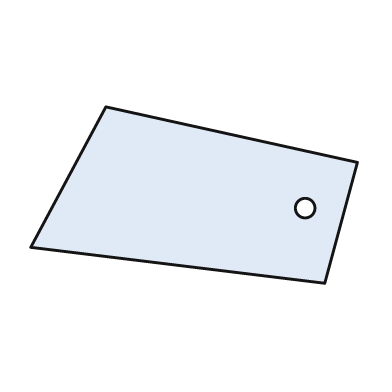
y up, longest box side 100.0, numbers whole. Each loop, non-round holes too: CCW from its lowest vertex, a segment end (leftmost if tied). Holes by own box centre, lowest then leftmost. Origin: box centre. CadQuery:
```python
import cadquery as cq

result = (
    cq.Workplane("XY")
    .moveTo(40.0, -27.0)
    .lineTo(50.0, 10.0)
    .lineTo(-27.0, 27.0)
    .lineTo(-50.0, -16.0)
    .close()
    .moveTo(34.0, -4.0)
    .circle(3.0)
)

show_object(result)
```